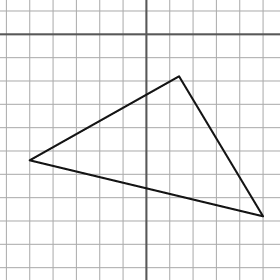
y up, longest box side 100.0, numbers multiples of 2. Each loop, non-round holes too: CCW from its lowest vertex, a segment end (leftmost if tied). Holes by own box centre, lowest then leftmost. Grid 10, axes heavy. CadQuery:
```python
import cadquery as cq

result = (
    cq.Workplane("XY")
    .moveTo(50.0, -78.0)
    .lineTo(14.0, -18.0)
    .lineTo(-50.0, -54.0)
    .close()
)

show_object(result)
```